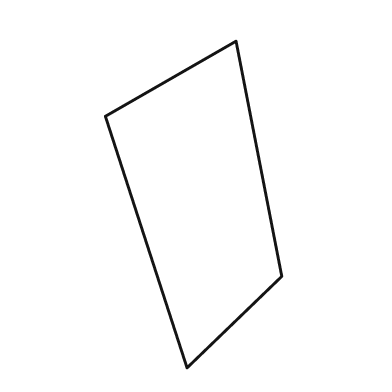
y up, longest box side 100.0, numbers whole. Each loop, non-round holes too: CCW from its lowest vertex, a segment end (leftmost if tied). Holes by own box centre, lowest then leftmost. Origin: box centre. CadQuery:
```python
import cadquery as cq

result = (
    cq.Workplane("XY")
    .moveTo(-2.0, -50.0)
    .lineTo(27.0, -22.0)
    .lineTo(13.0, 50.0)
    .lineTo(-27.0, 27.0)
    .close()
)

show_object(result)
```